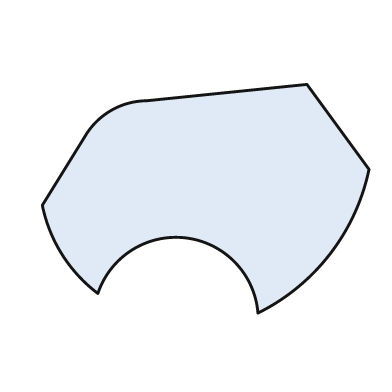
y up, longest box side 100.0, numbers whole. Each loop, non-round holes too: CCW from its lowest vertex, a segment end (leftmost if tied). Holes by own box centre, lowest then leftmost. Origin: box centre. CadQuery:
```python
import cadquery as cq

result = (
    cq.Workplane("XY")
    .moveTo(16.0, -35.0)
    .threePointArc((38.0, -17.0), (50.0, 9.0))
    .lineTo(31.0, 35.0)
    .lineTo(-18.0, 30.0)
    .threePointArc((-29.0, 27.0), (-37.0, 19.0))
    .lineTo(-50.0, -2.0)
    .threePointArc((-44.0, -17.0), (-33.0, -29.0))
    .threePointArc((-6.0, -12.0), (16.0, -35.0))
    .close()
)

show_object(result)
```